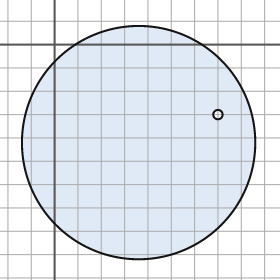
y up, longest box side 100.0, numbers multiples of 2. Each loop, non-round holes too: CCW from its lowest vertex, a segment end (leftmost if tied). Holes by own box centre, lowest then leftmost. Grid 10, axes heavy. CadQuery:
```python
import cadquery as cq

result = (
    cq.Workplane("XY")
    .moveTo(36.0, -42.0)
    .circle(50.0)
    .moveTo(70.0, -30.0)
    .circle(2.0)
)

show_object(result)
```